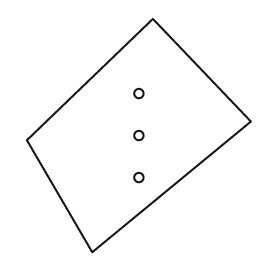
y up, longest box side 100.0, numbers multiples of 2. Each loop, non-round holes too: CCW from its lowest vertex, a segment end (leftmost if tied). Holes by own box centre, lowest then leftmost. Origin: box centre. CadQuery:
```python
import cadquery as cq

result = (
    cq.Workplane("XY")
    .moveTo(-20.0, -50.0)
    .lineTo(48.0, 6.0)
    .lineTo(6.0, 50.0)
    .lineTo(-48.0, -2.0)
    .close()
    .moveTo(0.0, -18.0)
    .circle(2.0)
    .moveTo(0.0, 0.0)
    .circle(2.0)
    .moveTo(0.0, 18.0)
    .circle(2.0)
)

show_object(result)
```